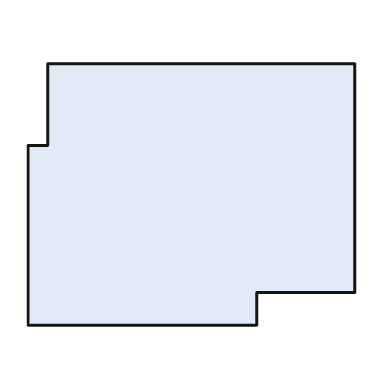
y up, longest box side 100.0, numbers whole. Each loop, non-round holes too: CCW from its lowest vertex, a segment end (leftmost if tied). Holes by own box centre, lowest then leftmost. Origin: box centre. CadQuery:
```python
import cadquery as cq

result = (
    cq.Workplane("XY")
    .moveTo(-50.0, -40.0)
    .lineTo(20.0, -40.0)
    .lineTo(20.0, -30.0)
    .lineTo(50.0, -30.0)
    .lineTo(50.0, 40.0)
    .lineTo(-44.0, 40.0)
    .lineTo(-44.0, 15.0)
    .lineTo(-50.0, 15.0)
    .close()
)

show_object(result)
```